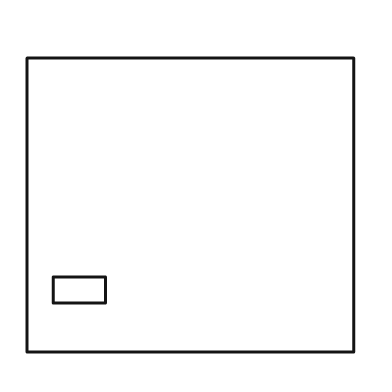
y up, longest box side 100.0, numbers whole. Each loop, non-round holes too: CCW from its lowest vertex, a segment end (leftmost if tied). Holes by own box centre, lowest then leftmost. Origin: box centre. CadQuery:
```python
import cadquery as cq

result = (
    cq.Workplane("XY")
    .moveTo(-50.0, -45.0)
    .lineTo(50.0, -45.0)
    .lineTo(50.0, 45.0)
    .lineTo(-50.0, 45.0)
    .close()
    .moveTo(-42.0, -30.0)
    .lineTo(-26.0, -30.0)
    .lineTo(-26.0, -22.0)
    .lineTo(-42.0, -22.0)
    .close()
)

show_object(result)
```